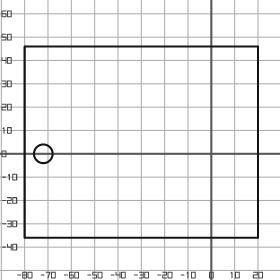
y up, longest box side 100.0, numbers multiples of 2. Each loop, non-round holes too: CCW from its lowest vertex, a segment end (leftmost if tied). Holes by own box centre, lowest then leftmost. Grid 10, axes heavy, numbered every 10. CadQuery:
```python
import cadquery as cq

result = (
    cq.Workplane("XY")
    .moveTo(-80.0, -36.0)
    .lineTo(20.0, -36.0)
    .lineTo(20.0, 46.0)
    .lineTo(-80.0, 46.0)
    .close()
    .moveTo(-72.0, 0.0)
    .circle(4.0)
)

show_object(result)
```